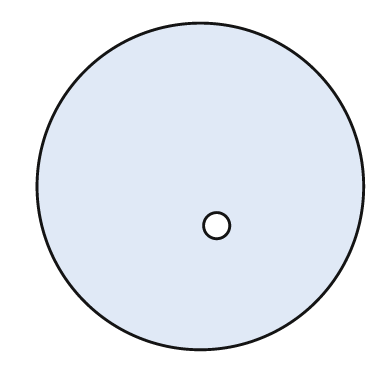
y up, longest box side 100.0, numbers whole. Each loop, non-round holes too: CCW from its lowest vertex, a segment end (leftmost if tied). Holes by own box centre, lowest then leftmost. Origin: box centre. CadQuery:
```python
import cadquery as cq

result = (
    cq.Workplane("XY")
    .moveTo(0.0, 0.0)
    .circle(50.0)
    .moveTo(5.0, -12.0)
    .circle(4.0)
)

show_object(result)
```